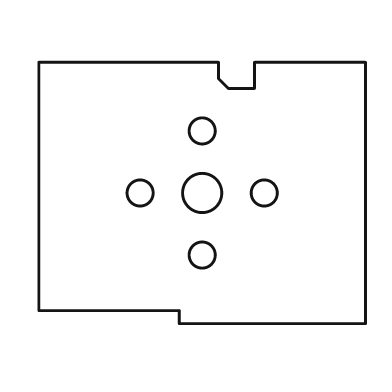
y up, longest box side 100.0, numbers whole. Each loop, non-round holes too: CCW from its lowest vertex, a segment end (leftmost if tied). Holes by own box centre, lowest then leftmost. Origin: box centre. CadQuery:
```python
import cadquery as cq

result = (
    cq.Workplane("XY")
    .moveTo(-7.0, -40.0)
    .lineTo(50.0, -40.0)
    .lineTo(50.0, 40.0)
    .lineTo(16.0, 40.0)
    .lineTo(16.0, 32.0)
    .lineTo(8.0, 32.0)
    .lineTo(5.0, 35.0)
    .lineTo(5.0, 40.0)
    .lineTo(-50.0, 40.0)
    .lineTo(-50.0, -36.0)
    .lineTo(-7.0, -36.0)
    .close()
    .moveTo(0.0, -19.0)
    .circle(4.0)
    .moveTo(-19.0, 0.0)
    .circle(4.0)
    .moveTo(0.0, 0.0)
    .circle(6.0)
    .moveTo(19.0, 0.0)
    .circle(4.0)
    .moveTo(0.0, 19.0)
    .circle(4.0)
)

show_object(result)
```